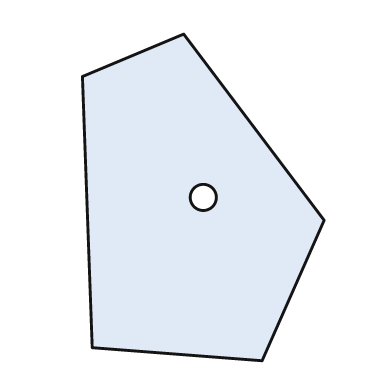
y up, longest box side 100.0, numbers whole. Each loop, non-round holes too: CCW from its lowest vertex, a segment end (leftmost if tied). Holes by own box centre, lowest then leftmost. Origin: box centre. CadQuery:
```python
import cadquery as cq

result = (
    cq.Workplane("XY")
    .moveTo(18.0, -50.0)
    .lineTo(37.0, -7.0)
    .lineTo(-6.0, 50.0)
    .lineTo(-37.0, 37.0)
    .lineTo(-34.0, -46.0)
    .close()
    .moveTo(0.0, 0.0)
    .circle(4.0)
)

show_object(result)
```